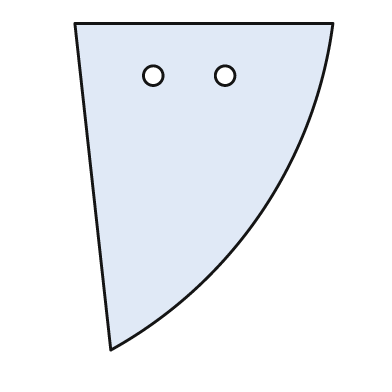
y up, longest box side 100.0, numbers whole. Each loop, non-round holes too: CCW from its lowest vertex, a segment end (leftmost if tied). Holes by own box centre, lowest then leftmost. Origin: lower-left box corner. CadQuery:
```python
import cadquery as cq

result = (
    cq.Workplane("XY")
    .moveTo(11.0, 0.0)
    .threePointArc((57.0, 42.0), (79.0, 100.0))
    .lineTo(0.0, 100.0)
    .close()
    .moveTo(24.0, 84.0)
    .circle(3.0)
    .moveTo(46.0, 84.0)
    .circle(3.0)
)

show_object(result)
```